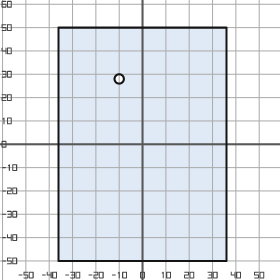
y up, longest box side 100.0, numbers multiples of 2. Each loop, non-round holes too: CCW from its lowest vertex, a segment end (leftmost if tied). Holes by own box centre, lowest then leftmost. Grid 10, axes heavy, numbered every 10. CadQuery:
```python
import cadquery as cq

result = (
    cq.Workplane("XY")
    .moveTo(-36.0, -50.0)
    .lineTo(36.0, -50.0)
    .lineTo(36.0, 50.0)
    .lineTo(-36.0, 50.0)
    .close()
    .moveTo(-10.0, 28.0)
    .circle(2.0)
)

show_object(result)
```